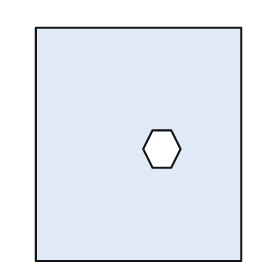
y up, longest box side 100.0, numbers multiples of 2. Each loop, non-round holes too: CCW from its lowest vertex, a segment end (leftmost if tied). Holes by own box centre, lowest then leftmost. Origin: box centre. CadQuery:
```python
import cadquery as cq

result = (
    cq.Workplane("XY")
    .moveTo(-44.0, -50.0)
    .lineTo(44.0, -50.0)
    .lineTo(44.0, 50.0)
    .lineTo(-44.0, 50.0)
    .close()
    .moveTo(6.0, -10.0)
    .lineTo(14.0, -10.0)
    .lineTo(18.0, -2.0)
    .lineTo(14.0, 6.0)
    .lineTo(6.0, 6.0)
    .lineTo(2.0, -2.0)
    .close()
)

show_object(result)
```